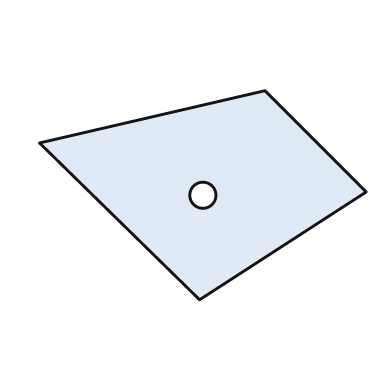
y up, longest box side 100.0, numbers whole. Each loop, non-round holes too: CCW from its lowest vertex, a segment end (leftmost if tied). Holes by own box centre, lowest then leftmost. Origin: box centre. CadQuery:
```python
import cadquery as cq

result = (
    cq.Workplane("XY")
    .moveTo(-1.0, -32.0)
    .lineTo(50.0, 1.0)
    .lineTo(19.0, 32.0)
    .lineTo(-50.0, 16.0)
    .close()
    .moveTo(0.0, 0.0)
    .circle(4.0)
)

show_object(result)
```